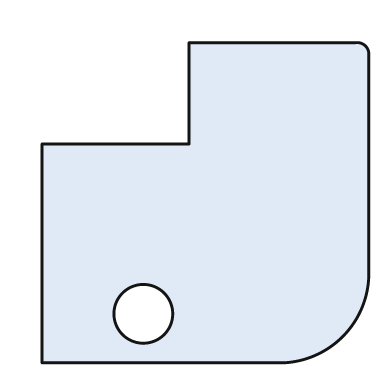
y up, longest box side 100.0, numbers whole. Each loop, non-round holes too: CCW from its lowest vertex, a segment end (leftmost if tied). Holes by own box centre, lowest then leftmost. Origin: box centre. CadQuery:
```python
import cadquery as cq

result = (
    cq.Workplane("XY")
    .moveTo(-50.0, -49.0)
    .lineTo(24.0, -49.0)
    .threePointArc((42.0, -41.0), (50.0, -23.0))
    .lineTo(50.0, 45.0)
    .threePointArc((49.0, 48.0), (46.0, 49.0))
    .lineTo(-5.0, 49.0)
    .lineTo(-5.0, 18.0)
    .lineTo(-50.0, 18.0)
    .close()
    .moveTo(-19.0, -34.0)
    .circle(9.0)
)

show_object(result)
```